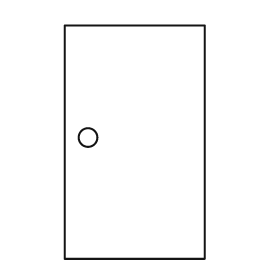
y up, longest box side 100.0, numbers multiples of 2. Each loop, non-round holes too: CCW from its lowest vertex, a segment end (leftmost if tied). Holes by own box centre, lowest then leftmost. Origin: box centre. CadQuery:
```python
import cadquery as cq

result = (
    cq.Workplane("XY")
    .moveTo(-30.0, -50.0)
    .lineTo(30.0, -50.0)
    .lineTo(30.0, 50.0)
    .lineTo(-30.0, 50.0)
    .close()
    .moveTo(-20.0, 2.0)
    .circle(4.0)
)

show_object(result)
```